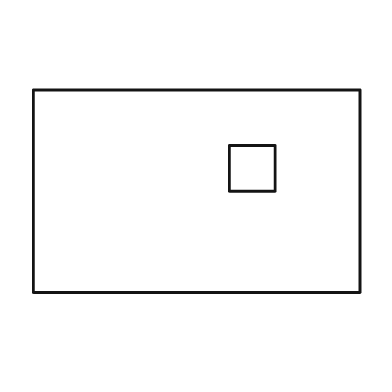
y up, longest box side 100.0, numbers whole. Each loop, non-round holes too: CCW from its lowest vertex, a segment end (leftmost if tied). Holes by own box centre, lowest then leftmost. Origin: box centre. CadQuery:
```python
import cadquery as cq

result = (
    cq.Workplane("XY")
    .moveTo(-50.0, -31.0)
    .lineTo(50.0, -31.0)
    .lineTo(50.0, 31.0)
    .lineTo(-50.0, 31.0)
    .close()
    .moveTo(10.0, 0.0)
    .lineTo(24.0, 0.0)
    .lineTo(24.0, 14.0)
    .lineTo(10.0, 14.0)
    .close()
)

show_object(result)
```